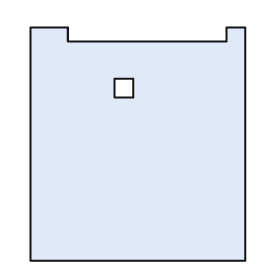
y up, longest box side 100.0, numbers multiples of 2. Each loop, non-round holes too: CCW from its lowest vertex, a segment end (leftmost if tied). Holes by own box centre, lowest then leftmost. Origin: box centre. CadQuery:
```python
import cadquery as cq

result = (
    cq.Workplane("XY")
    .moveTo(-46.0, -50.0)
    .lineTo(46.0, -50.0)
    .lineTo(46.0, 50.0)
    .lineTo(38.0, 50.0)
    .lineTo(38.0, 44.0)
    .lineTo(-30.0, 44.0)
    .lineTo(-30.0, 50.0)
    .lineTo(-46.0, 50.0)
    .close()
    .moveTo(-10.0, 20.0)
    .lineTo(-2.0, 20.0)
    .lineTo(-2.0, 28.0)
    .lineTo(-10.0, 28.0)
    .close()
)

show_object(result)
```